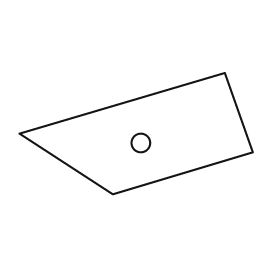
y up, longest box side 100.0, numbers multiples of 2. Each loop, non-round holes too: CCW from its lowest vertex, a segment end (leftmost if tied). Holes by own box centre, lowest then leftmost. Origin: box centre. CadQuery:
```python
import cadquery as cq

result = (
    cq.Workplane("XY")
    .moveTo(-10.0, -26.0)
    .lineTo(50.0, -8.0)
    .lineTo(38.0, 26.0)
    .lineTo(-50.0, 0.0)
    .close()
    .moveTo(2.0, -4.0)
    .circle(4.0)
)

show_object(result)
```